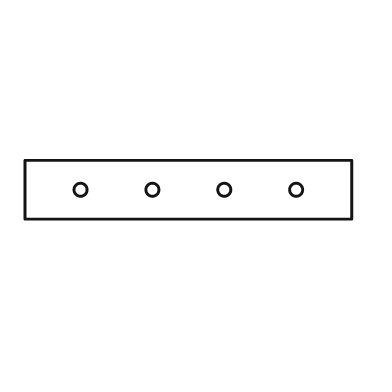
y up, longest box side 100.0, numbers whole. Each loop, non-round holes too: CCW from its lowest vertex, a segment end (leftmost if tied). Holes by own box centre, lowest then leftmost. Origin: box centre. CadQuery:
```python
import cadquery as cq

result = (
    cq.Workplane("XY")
    .moveTo(-50.0, -9.0)
    .lineTo(50.0, -9.0)
    .lineTo(50.0, 9.0)
    .lineTo(-50.0, 9.0)
    .close()
    .moveTo(-33.0, 0.0)
    .circle(2.0)
    .moveTo(-11.0, 0.0)
    .circle(2.0)
    .moveTo(11.0, 0.0)
    .circle(2.0)
    .moveTo(33.0, 0.0)
    .circle(2.0)
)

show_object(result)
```